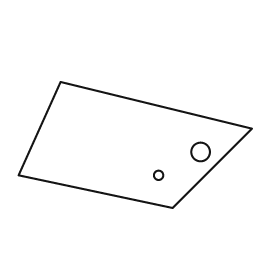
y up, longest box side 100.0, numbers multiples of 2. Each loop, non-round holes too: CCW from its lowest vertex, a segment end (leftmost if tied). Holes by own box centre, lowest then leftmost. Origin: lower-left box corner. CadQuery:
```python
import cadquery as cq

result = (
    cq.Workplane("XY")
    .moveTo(66.0, 0.0)
    .lineTo(100.0, 34.0)
    .lineTo(18.0, 54.0)
    .lineTo(0.0, 14.0)
    .close()
    .moveTo(60.0, 14.0)
    .circle(2.0)
    .moveTo(78.0, 24.0)
    .circle(4.0)
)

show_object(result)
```